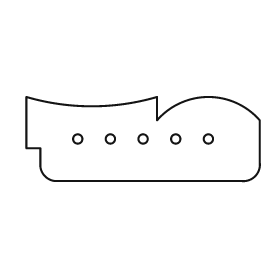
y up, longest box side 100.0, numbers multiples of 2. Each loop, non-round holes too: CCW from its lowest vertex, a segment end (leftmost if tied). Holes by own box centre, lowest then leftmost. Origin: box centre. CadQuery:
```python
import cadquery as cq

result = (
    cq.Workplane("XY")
    .moveTo(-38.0, -18.0)
    .lineTo(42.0, -18.0)
    .threePointArc((48.0, -16.0), (50.0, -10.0))
    .lineTo(50.0, 8.0)
    .threePointArc((28.0, 18.0), (6.0, 8.0))
    .lineTo(6.0, 18.0)
    .threePointArc((-22.0, 14.0), (-50.0, 18.0))
    .lineTo(-50.0, -4.0)
    .lineTo(-44.0, -4.0)
    .lineTo(-44.0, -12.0)
    .threePointArc((-42.0, -16.0), (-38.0, -18.0))
    .close()
    .moveTo(-28.0, 0.0)
    .circle(2.0)
    .moveTo(-14.0, 0.0)
    .circle(2.0)
    .moveTo(0.0, 0.0)
    .circle(2.0)
    .moveTo(14.0, 0.0)
    .circle(2.0)
    .moveTo(28.0, 0.0)
    .circle(2.0)
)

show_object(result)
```